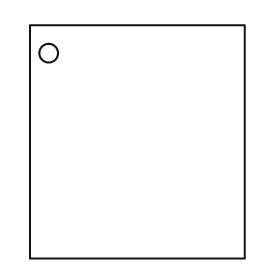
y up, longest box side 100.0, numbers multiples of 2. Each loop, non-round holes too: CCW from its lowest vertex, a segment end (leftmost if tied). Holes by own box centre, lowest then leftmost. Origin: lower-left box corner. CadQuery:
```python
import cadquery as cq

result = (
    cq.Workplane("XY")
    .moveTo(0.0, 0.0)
    .lineTo(92.0, 0.0)
    .lineTo(92.0, 100.0)
    .lineTo(0.0, 100.0)
    .close()
    .moveTo(8.0, 88.0)
    .circle(4.0)
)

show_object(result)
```